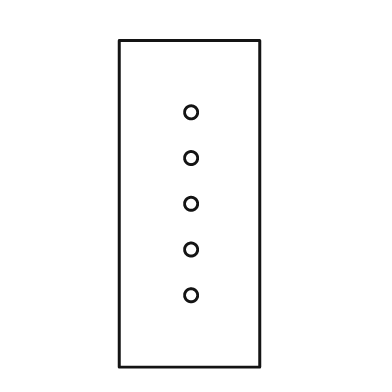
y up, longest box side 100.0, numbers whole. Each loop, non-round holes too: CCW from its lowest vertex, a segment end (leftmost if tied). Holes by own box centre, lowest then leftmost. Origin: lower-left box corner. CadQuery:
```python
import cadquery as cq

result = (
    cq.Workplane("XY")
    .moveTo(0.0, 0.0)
    .lineTo(43.0, 0.0)
    .lineTo(43.0, 100.0)
    .lineTo(0.0, 100.0)
    .close()
    .moveTo(22.0, 22.0)
    .circle(2.0)
    .moveTo(22.0, 36.0)
    .circle(2.0)
    .moveTo(22.0, 50.0)
    .circle(2.0)
    .moveTo(22.0, 64.0)
    .circle(2.0)
    .moveTo(22.0, 78.0)
    .circle(2.0)
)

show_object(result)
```